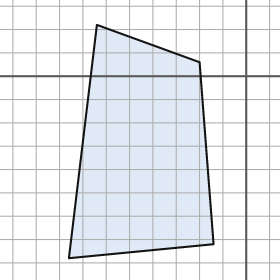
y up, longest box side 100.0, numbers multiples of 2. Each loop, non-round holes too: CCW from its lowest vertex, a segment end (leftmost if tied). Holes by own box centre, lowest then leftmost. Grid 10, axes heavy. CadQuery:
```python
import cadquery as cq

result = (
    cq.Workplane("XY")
    .moveTo(-76.0, -78.0)
    .lineTo(-14.0, -72.0)
    .lineTo(-20.0, 6.0)
    .lineTo(-64.0, 22.0)
    .close()
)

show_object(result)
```